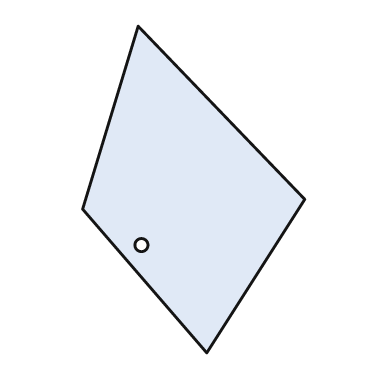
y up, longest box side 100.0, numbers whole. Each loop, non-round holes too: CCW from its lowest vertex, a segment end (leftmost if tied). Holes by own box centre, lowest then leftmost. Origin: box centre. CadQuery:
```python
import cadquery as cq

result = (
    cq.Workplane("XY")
    .moveTo(4.0, -50.0)
    .lineTo(34.0, -3.0)
    .lineTo(-17.0, 50.0)
    .lineTo(-34.0, -6.0)
    .close()
    .moveTo(-16.0, -17.0)
    .circle(2.0)
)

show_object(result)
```